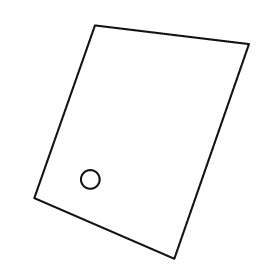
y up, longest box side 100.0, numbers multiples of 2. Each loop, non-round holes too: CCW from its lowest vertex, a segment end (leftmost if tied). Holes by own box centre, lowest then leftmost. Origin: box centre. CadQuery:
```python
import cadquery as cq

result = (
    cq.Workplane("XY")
    .moveTo(14.0, -50.0)
    .lineTo(46.0, 42.0)
    .lineTo(-20.0, 50.0)
    .lineTo(-46.0, -24.0)
    .close()
    .moveTo(-22.0, -16.0)
    .circle(4.0)
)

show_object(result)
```